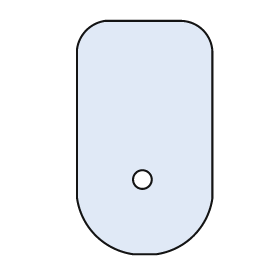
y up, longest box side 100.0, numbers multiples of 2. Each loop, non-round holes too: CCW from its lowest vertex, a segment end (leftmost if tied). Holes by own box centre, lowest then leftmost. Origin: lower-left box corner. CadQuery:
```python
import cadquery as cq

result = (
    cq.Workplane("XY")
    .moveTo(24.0, 0.0)
    .lineTo(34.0, 0.0)
    .threePointArc((50.0, 8.0), (58.0, 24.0))
    .lineTo(58.0, 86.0)
    .threePointArc((54.0, 96.0), (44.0, 100.0))
    .lineTo(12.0, 100.0)
    .threePointArc((4.0, 96.0), (0.0, 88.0))
    .lineTo(0.0, 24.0)
    .threePointArc((8.0, 8.0), (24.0, 0.0))
    .close()
    .moveTo(28.0, 32.0)
    .circle(4.0)
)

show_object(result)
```